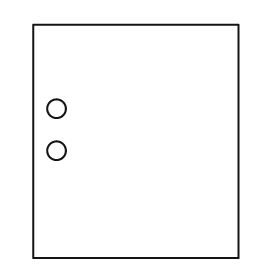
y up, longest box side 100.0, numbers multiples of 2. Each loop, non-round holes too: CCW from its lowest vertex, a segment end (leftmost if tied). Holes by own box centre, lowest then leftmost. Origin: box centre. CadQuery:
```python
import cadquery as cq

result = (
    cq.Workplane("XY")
    .moveTo(-44.0, -50.0)
    .lineTo(44.0, -50.0)
    .lineTo(44.0, 50.0)
    .lineTo(-44.0, 50.0)
    .close()
    .moveTo(-34.0, -4.0)
    .circle(4.0)
    .moveTo(-34.0, 14.0)
    .circle(4.0)
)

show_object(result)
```